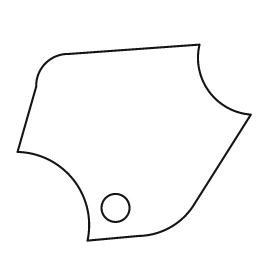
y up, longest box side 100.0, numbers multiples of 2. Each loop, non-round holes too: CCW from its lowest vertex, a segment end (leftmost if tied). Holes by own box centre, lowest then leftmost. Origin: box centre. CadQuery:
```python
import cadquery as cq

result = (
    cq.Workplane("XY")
    .moveTo(-20.0, -42.0)
    .lineTo(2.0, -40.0)
    .threePointArc((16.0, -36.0), (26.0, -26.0))
    .lineTo(50.0, 12.0)
    .threePointArc((32.0, 22.0), (28.0, 42.0))
    .lineTo(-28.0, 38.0)
    .threePointArc((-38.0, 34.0), (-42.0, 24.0))
    .lineTo(-50.0, -4.0)
    .threePointArc((-26.0, -16.0), (-20.0, -42.0))
    .close()
    .moveTo(-8.0, -28.0)
    .circle(6.0)
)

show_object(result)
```